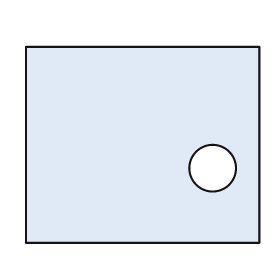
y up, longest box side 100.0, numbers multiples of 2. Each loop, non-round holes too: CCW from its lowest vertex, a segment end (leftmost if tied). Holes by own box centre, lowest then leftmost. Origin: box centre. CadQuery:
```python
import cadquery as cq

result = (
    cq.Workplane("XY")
    .moveTo(-50.0, -42.0)
    .lineTo(50.0, -42.0)
    .lineTo(50.0, 42.0)
    .lineTo(-50.0, 42.0)
    .close()
    .moveTo(30.0, -10.0)
    .circle(10.0)
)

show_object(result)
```